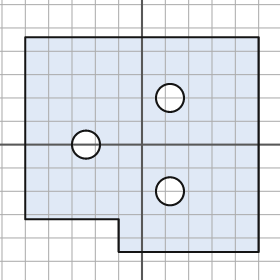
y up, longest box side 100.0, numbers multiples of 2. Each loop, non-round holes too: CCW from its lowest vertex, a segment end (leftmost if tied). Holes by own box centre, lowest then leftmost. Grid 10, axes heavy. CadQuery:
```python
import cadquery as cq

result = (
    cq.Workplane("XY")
    .moveTo(-10.0, -46.0)
    .lineTo(50.0, -46.0)
    .lineTo(50.0, 46.0)
    .lineTo(-50.0, 46.0)
    .lineTo(-50.0, -32.0)
    .lineTo(-10.0, -32.0)
    .close()
    .moveTo(12.0, -20.0)
    .circle(6.0)
    .moveTo(-24.0, 0.0)
    .circle(6.0)
    .moveTo(12.0, 20.0)
    .circle(6.0)
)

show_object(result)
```